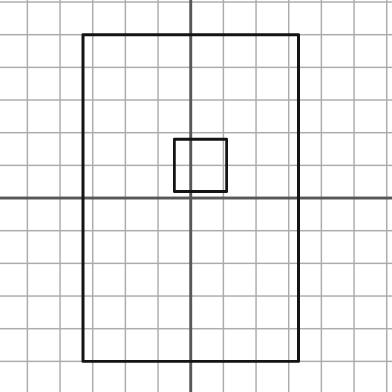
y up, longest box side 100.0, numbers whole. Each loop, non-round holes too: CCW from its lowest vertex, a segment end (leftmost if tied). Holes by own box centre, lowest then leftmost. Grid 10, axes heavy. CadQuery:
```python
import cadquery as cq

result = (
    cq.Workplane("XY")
    .moveTo(-33.0, -50.0)
    .lineTo(33.0, -50.0)
    .lineTo(33.0, 50.0)
    .lineTo(-33.0, 50.0)
    .close()
    .moveTo(-5.0, 2.0)
    .lineTo(11.0, 2.0)
    .lineTo(11.0, 18.0)
    .lineTo(-5.0, 18.0)
    .close()
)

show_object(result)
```